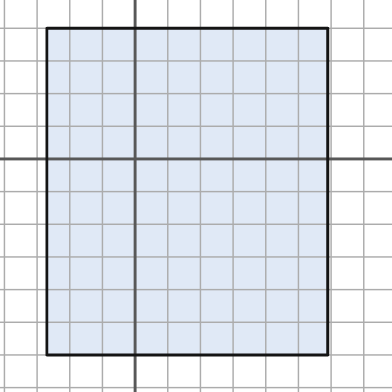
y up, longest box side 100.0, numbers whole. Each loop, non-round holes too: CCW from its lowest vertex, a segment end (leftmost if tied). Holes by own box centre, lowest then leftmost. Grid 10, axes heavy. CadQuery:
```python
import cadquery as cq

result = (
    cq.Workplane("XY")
    .moveTo(-27.0, -60.0)
    .lineTo(59.0, -60.0)
    .lineTo(59.0, 40.0)
    .lineTo(-27.0, 40.0)
    .close()
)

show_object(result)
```